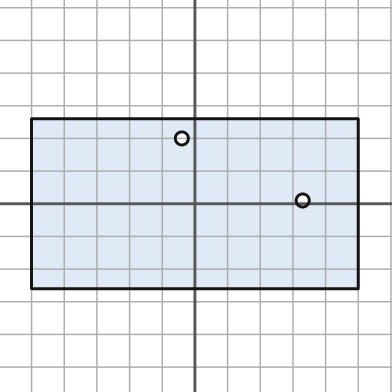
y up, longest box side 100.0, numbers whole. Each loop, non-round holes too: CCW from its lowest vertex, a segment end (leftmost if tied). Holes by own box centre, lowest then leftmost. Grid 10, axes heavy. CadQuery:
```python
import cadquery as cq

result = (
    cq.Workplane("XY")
    .moveTo(-50.0, -26.0)
    .lineTo(50.0, -26.0)
    .lineTo(50.0, 26.0)
    .lineTo(-50.0, 26.0)
    .close()
    .moveTo(33.0, 1.0)
    .circle(2.0)
    .moveTo(-4.0, 20.0)
    .circle(2.0)
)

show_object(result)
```